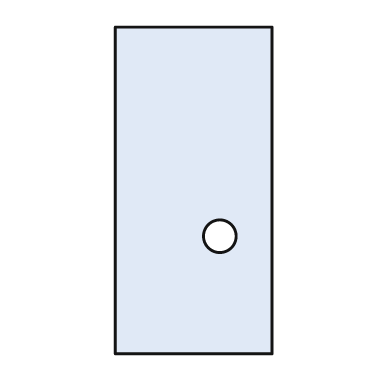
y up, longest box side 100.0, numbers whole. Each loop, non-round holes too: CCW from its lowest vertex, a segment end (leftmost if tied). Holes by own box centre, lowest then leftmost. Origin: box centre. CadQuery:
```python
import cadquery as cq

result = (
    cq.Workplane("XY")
    .moveTo(-24.0, -50.0)
    .lineTo(24.0, -50.0)
    .lineTo(24.0, 50.0)
    .lineTo(-24.0, 50.0)
    .close()
    .moveTo(8.0, -14.0)
    .circle(5.0)
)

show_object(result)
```